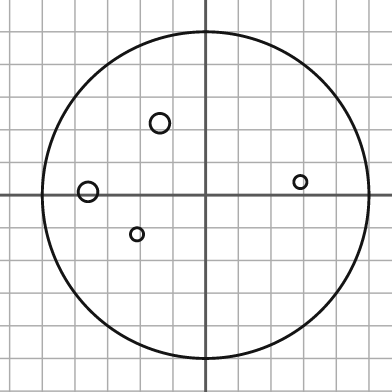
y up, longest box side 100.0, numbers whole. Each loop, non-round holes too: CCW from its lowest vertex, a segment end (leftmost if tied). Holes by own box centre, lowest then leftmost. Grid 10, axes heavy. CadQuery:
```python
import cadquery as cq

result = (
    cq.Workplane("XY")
    .moveTo(0.0, 0.0)
    .circle(50.0)
    .moveTo(-21.0, -12.0)
    .circle(2.0)
    .moveTo(-36.0, 1.0)
    .circle(3.0)
    .moveTo(29.0, 4.0)
    .circle(2.0)
    .moveTo(-14.0, 22.0)
    .circle(3.0)
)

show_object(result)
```